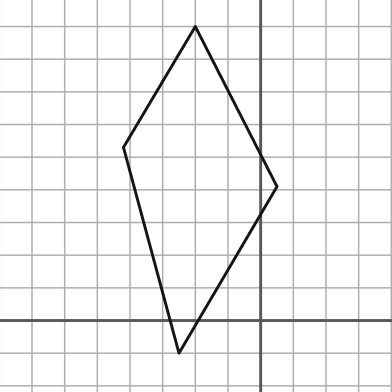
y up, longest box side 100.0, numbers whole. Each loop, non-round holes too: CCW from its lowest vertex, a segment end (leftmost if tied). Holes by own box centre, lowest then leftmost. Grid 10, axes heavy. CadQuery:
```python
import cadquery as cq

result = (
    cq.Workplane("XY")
    .moveTo(-25.0, -10.0)
    .lineTo(5.0, 41.0)
    .lineTo(-20.0, 90.0)
    .lineTo(-42.0, 53.0)
    .close()
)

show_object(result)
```